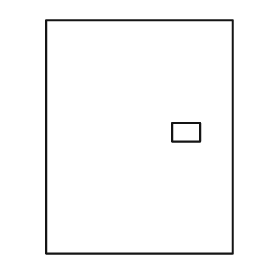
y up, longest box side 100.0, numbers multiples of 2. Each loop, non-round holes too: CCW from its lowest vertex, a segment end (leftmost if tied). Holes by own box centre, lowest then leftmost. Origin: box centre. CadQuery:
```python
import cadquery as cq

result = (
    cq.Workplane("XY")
    .moveTo(-40.0, -50.0)
    .lineTo(40.0, -50.0)
    .lineTo(40.0, 50.0)
    .lineTo(-40.0, 50.0)
    .close()
    .moveTo(14.0, -2.0)
    .lineTo(26.0, -2.0)
    .lineTo(26.0, 6.0)
    .lineTo(14.0, 6.0)
    .close()
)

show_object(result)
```